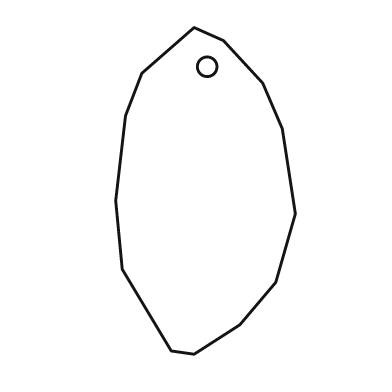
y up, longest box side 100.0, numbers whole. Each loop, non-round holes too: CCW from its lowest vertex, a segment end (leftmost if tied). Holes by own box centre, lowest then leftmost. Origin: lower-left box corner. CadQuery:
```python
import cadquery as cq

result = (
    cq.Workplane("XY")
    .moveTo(24.0, 0.0)
    .lineTo(38.0, 9.0)
    .lineTo(49.0, 22.0)
    .lineTo(55.0, 43.0)
    .lineTo(51.0, 69.0)
    .lineTo(45.0, 83.0)
    .lineTo(33.0, 96.0)
    .lineTo(24.0, 100.0)
    .lineTo(8.0, 86.0)
    .lineTo(3.0, 73.0)
    .lineTo(0.0, 47.0)
    .lineTo(2.0, 26.0)
    .lineTo(17.0, 1.0)
    .close()
    .moveTo(28.0, 88.0)
    .circle(3.0)
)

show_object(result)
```